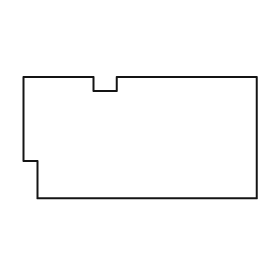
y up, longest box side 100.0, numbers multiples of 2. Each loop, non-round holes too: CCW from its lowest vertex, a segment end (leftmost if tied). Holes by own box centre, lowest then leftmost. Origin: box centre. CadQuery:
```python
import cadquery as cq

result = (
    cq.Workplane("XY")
    .moveTo(-44.0, -26.0)
    .lineTo(50.0, -26.0)
    .lineTo(50.0, 26.0)
    .lineTo(-10.0, 26.0)
    .lineTo(-10.0, 20.0)
    .lineTo(-20.0, 20.0)
    .lineTo(-20.0, 26.0)
    .lineTo(-50.0, 26.0)
    .lineTo(-50.0, -10.0)
    .lineTo(-44.0, -10.0)
    .close()
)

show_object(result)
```